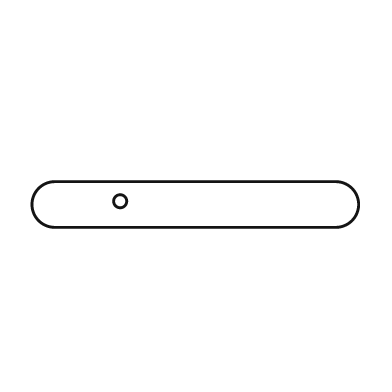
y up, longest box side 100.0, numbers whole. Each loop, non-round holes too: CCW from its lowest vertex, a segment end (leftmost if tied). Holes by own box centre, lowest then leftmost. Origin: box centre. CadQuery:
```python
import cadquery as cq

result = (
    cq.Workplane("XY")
    .moveTo(-43.0, -7.0)
    .lineTo(43.0, -7.0)
    .threePointArc((50.0, 0.0), (43.0, 7.0))
    .lineTo(-43.0, 7.0)
    .threePointArc((-50.0, 0.0), (-43.0, -7.0))
    .close()
    .moveTo(-23.0, 1.0)
    .circle(2.0)
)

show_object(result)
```